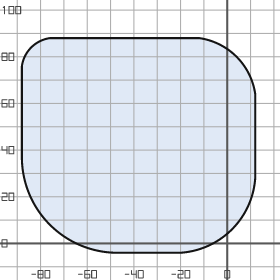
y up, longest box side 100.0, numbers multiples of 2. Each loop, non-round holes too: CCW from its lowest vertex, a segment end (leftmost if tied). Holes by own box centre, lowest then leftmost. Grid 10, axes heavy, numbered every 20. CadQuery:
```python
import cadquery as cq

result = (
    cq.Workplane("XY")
    .moveTo(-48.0, -4.0)
    .lineTo(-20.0, -4.0)
    .threePointArc((2.0, 6.0), (12.0, 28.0))
    .lineTo(12.0, 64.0)
    .threePointArc((4.0, 80.0), (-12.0, 88.0))
    .lineTo(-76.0, 88.0)
    .threePointArc((-84.0, 84.0), (-88.0, 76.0))
    .lineTo(-88.0, 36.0)
    .threePointArc((-76.0, 8.0), (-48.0, -4.0))
    .close()
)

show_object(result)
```